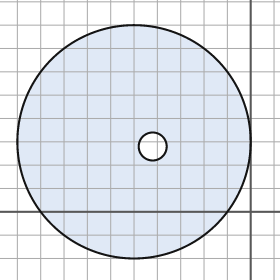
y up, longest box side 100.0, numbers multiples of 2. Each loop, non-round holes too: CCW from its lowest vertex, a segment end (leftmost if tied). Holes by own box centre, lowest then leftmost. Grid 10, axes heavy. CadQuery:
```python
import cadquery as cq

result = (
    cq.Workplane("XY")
    .moveTo(-50.0, 30.0)
    .circle(50.0)
    .moveTo(-42.0, 28.0)
    .circle(6.0)
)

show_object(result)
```